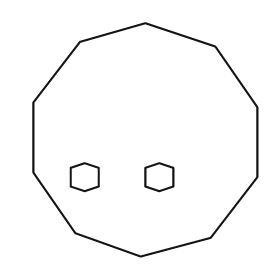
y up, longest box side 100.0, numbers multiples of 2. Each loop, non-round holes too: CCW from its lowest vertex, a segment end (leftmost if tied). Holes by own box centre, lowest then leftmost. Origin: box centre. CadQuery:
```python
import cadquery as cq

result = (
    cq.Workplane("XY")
    .moveTo(-2.0, -50.0)
    .lineTo(28.0, -42.0)
    .lineTo(48.0, -16.0)
    .lineTo(48.0, 14.0)
    .lineTo(30.0, 40.0)
    .lineTo(0.0, 50.0)
    .lineTo(-28.0, 42.0)
    .lineTo(-48.0, 16.0)
    .lineTo(-48.0, -14.0)
    .lineTo(-30.0, -40.0)
    .close()
    .moveTo(-26.0, -22.0)
    .lineTo(-20.0, -20.0)
    .lineTo(-20.0, -12.0)
    .lineTo(-26.0, -10.0)
    .lineTo(-32.0, -12.0)
    .lineTo(-32.0, -20.0)
    .close()
    .moveTo(6.0, -22.0)
    .lineTo(12.0, -20.0)
    .lineTo(12.0, -12.0)
    .lineTo(6.0, -10.0)
    .lineTo(0.0, -12.0)
    .lineTo(0.0, -20.0)
    .close()
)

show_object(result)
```